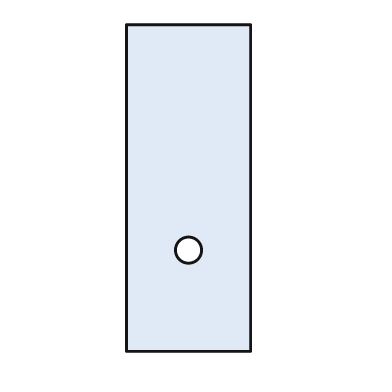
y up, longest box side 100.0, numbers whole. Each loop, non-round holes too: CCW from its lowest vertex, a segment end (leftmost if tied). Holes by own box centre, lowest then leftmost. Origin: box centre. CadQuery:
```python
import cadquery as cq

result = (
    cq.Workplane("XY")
    .moveTo(-19.0, -50.0)
    .lineTo(19.0, -50.0)
    .lineTo(19.0, 50.0)
    .lineTo(-19.0, 50.0)
    .close()
    .moveTo(0.0, -19.0)
    .circle(4.0)
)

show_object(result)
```